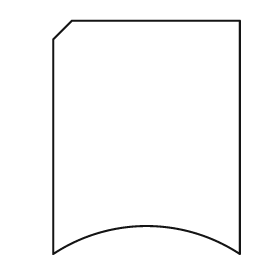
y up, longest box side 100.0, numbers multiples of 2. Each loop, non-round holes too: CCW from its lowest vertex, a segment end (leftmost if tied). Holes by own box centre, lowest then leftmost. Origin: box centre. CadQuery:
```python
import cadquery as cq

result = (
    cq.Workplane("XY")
    .moveTo(-40.0, -50.0)
    .threePointArc((0.0, -38.0), (40.0, -50.0))
    .lineTo(40.0, 50.0)
    .lineTo(-32.0, 50.0)
    .lineTo(-40.0, 42.0)
    .close()
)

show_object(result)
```